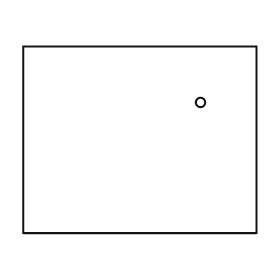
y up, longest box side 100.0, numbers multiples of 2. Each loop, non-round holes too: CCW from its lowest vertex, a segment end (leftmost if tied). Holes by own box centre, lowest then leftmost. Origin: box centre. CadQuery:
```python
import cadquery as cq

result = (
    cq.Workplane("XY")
    .moveTo(-50.0, -40.0)
    .lineTo(50.0, -40.0)
    .lineTo(50.0, 40.0)
    .lineTo(-50.0, 40.0)
    .close()
    .moveTo(26.0, 16.0)
    .circle(2.0)
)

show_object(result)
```